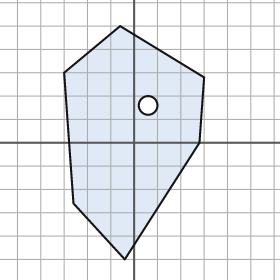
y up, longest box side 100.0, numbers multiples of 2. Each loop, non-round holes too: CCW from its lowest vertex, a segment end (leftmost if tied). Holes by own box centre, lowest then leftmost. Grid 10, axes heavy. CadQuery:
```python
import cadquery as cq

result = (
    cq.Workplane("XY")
    .moveTo(-4.0, -50.0)
    .lineTo(28.0, 0.0)
    .lineTo(30.0, 28.0)
    .lineTo(-6.0, 50.0)
    .lineTo(-30.0, 30.0)
    .lineTo(-26.0, -26.0)
    .close()
    .moveTo(6.0, 16.0)
    .circle(4.0)
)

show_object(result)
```